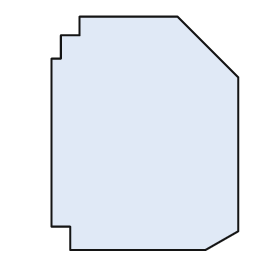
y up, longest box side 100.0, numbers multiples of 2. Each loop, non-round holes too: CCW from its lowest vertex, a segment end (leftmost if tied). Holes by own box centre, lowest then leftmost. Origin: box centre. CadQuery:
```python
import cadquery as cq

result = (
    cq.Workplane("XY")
    .moveTo(-32.0, -50.0)
    .lineTo(26.0, -50.0)
    .lineTo(40.0, -42.0)
    .lineTo(40.0, 24.0)
    .lineTo(14.0, 50.0)
    .lineTo(-28.0, 50.0)
    .lineTo(-28.0, 42.0)
    .lineTo(-36.0, 42.0)
    .lineTo(-36.0, 32.0)
    .lineTo(-40.0, 32.0)
    .lineTo(-40.0, -40.0)
    .lineTo(-32.0, -40.0)
    .close()
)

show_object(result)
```